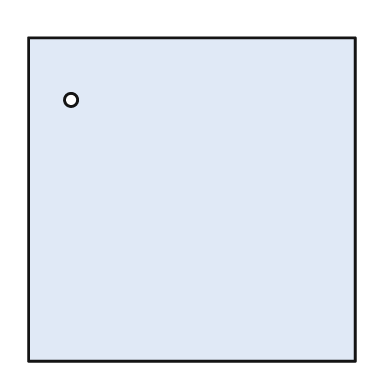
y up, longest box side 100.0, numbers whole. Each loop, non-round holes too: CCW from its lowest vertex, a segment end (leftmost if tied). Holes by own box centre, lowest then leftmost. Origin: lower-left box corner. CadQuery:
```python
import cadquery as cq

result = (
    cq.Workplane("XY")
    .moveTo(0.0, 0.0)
    .lineTo(100.0, 0.0)
    .lineTo(100.0, 99.0)
    .lineTo(0.0, 99.0)
    .close()
    .moveTo(13.0, 80.0)
    .circle(2.0)
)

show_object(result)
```